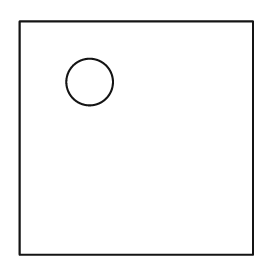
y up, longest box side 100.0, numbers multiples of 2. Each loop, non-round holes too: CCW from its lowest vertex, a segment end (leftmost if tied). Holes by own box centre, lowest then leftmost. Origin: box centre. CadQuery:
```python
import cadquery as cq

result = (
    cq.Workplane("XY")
    .moveTo(-50.0, -50.0)
    .lineTo(50.0, -50.0)
    .lineTo(50.0, 50.0)
    .lineTo(-50.0, 50.0)
    .close()
    .moveTo(-20.0, 24.0)
    .circle(10.0)
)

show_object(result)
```